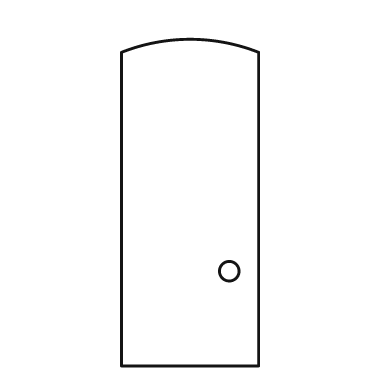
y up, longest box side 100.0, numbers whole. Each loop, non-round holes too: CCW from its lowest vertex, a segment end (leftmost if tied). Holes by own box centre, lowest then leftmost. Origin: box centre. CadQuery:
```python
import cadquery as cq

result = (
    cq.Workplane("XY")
    .moveTo(-21.0, -50.0)
    .lineTo(21.0, -50.0)
    .lineTo(21.0, 46.0)
    .threePointArc((0.0, 50.0), (-21.0, 46.0))
    .close()
    .moveTo(12.0, -21.0)
    .circle(3.0)
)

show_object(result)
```